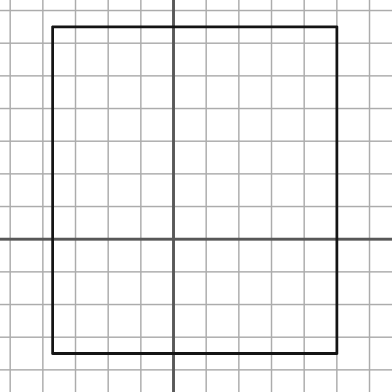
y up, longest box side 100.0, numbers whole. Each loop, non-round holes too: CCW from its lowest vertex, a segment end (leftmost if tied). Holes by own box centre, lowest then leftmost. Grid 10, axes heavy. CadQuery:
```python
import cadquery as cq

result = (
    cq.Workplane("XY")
    .moveTo(-37.0, -35.0)
    .lineTo(50.0, -35.0)
    .lineTo(50.0, 65.0)
    .lineTo(-37.0, 65.0)
    .close()
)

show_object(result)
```